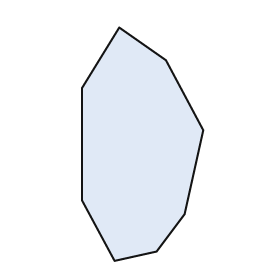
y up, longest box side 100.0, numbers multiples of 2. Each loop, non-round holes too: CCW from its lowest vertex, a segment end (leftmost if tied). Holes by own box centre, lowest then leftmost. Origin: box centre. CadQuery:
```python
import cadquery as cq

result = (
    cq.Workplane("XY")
    .moveTo(-12.0, -50.0)
    .lineTo(6.0, -46.0)
    .lineTo(18.0, -30.0)
    .lineTo(26.0, 6.0)
    .lineTo(10.0, 36.0)
    .lineTo(-10.0, 50.0)
    .lineTo(-26.0, 24.0)
    .lineTo(-26.0, -24.0)
    .close()
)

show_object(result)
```